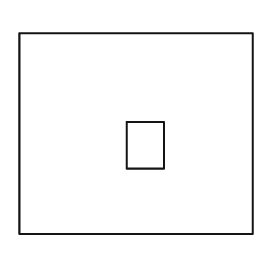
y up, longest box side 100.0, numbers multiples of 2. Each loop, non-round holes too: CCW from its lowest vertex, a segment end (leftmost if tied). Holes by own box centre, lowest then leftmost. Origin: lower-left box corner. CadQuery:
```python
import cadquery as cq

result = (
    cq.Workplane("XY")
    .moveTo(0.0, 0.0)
    .lineTo(100.0, 0.0)
    .lineTo(100.0, 86.0)
    .lineTo(0.0, 86.0)
    .close()
    .moveTo(46.0, 28.0)
    .lineTo(62.0, 28.0)
    .lineTo(62.0, 48.0)
    .lineTo(46.0, 48.0)
    .close()
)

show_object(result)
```